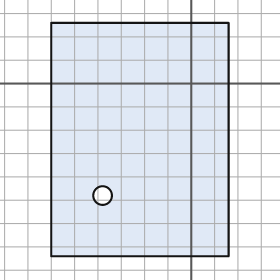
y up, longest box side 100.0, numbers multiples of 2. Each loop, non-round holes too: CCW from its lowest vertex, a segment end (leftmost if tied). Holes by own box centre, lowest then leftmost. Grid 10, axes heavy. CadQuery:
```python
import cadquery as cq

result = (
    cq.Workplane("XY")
    .moveTo(-60.0, -74.0)
    .lineTo(16.0, -74.0)
    .lineTo(16.0, 26.0)
    .lineTo(-60.0, 26.0)
    .close()
    .moveTo(-38.0, -48.0)
    .circle(4.0)
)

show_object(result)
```